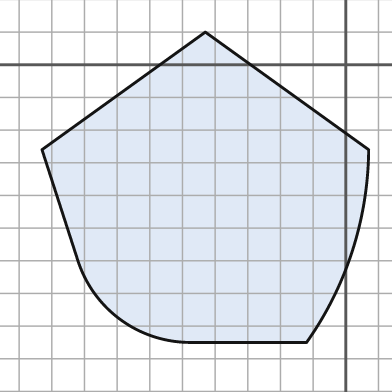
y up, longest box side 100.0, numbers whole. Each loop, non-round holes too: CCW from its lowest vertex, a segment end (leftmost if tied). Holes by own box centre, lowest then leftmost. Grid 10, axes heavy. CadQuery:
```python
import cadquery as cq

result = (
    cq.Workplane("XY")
    .moveTo(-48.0, -85.0)
    .lineTo(-12.0, -85.0)
    .threePointArc((2.0, -57.0), (7.0, -26.0))
    .lineTo(-43.0, 10.0)
    .lineTo(-93.0, -26.0)
    .lineTo(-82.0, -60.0)
    .threePointArc((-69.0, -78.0), (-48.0, -85.0))
    .close()
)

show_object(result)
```